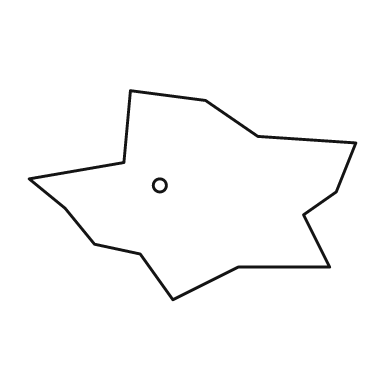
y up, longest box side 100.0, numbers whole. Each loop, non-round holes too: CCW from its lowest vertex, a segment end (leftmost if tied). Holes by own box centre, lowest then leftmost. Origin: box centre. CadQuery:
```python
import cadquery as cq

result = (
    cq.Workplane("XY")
    .moveTo(-6.0, -32.0)
    .lineTo(14.0, -22.0)
    .lineTo(42.0, -22.0)
    .lineTo(34.0, -6.0)
    .lineTo(44.0, 1.0)
    .lineTo(50.0, 16.0)
    .lineTo(20.0, 18.0)
    .lineTo(4.0, 29.0)
    .lineTo(-19.0, 32.0)
    .lineTo(-21.0, 10.0)
    .lineTo(-50.0, 5.0)
    .lineTo(-39.0, -4.0)
    .lineTo(-30.0, -15.0)
    .lineTo(-16.0, -18.0)
    .close()
    .moveTo(-10.0, 3.0)
    .circle(2.0)
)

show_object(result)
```